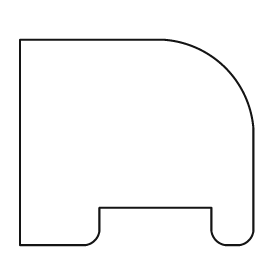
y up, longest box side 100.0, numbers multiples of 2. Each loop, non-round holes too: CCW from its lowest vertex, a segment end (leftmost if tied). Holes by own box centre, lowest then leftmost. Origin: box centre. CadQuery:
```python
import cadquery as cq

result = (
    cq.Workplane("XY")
    .moveTo(-50.0, -44.0)
    .lineTo(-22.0, -44.0)
    .threePointArc((-18.0, -42.0), (-16.0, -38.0))
    .lineTo(-16.0, -28.0)
    .lineTo(32.0, -28.0)
    .lineTo(32.0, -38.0)
    .threePointArc((34.0, -42.0), (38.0, -44.0))
    .lineTo(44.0, -44.0)
    .threePointArc((48.0, -42.0), (50.0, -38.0))
    .lineTo(50.0, 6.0)
    .threePointArc((38.0, 32.0), (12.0, 44.0))
    .lineTo(-50.0, 44.0)
    .close()
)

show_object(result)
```